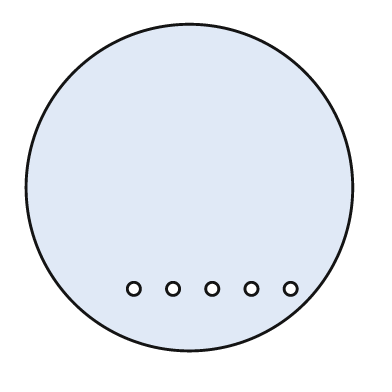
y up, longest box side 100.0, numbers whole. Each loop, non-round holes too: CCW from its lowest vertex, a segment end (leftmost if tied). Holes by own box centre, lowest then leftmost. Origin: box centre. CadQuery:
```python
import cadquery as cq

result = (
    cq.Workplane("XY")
    .moveTo(0.0, 0.0)
    .circle(50.0)
    .moveTo(-17.0, -31.0)
    .circle(2.0)
    .moveTo(-5.0, -31.0)
    .circle(2.0)
    .moveTo(7.0, -31.0)
    .circle(2.0)
    .moveTo(19.0, -31.0)
    .circle(2.0)
    .moveTo(31.0, -31.0)
    .circle(2.0)
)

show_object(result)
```